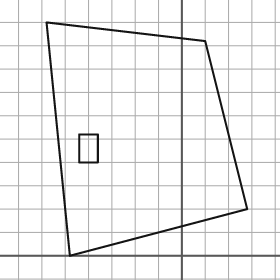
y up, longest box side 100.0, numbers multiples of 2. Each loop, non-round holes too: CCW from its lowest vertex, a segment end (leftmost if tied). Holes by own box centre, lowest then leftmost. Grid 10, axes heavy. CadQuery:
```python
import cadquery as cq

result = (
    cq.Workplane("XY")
    .moveTo(-48.0, 0.0)
    .lineTo(28.0, 20.0)
    .lineTo(10.0, 92.0)
    .lineTo(-58.0, 100.0)
    .close()
    .moveTo(-44.0, 40.0)
    .lineTo(-36.0, 40.0)
    .lineTo(-36.0, 52.0)
    .lineTo(-44.0, 52.0)
    .close()
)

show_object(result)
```